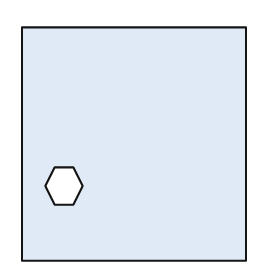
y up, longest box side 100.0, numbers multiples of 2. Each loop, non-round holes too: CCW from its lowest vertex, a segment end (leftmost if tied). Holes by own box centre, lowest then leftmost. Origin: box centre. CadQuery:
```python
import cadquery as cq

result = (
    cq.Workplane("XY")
    .moveTo(-48.0, -50.0)
    .lineTo(48.0, -50.0)
    .lineTo(48.0, 50.0)
    .lineTo(-48.0, 50.0)
    .close()
    .moveTo(-34.0, -26.0)
    .lineTo(-26.0, -26.0)
    .lineTo(-22.0, -18.0)
    .lineTo(-26.0, -10.0)
    .lineTo(-34.0, -10.0)
    .lineTo(-38.0, -18.0)
    .close()
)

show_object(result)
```